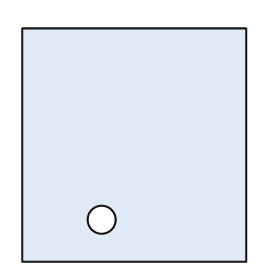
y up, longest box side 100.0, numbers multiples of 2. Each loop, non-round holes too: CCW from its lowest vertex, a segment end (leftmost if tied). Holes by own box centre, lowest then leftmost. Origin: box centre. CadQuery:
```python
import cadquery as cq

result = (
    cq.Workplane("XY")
    .moveTo(-48.0, -50.0)
    .lineTo(48.0, -50.0)
    .lineTo(48.0, 50.0)
    .lineTo(-48.0, 50.0)
    .close()
    .moveTo(-14.0, -32.0)
    .circle(6.0)
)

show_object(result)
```